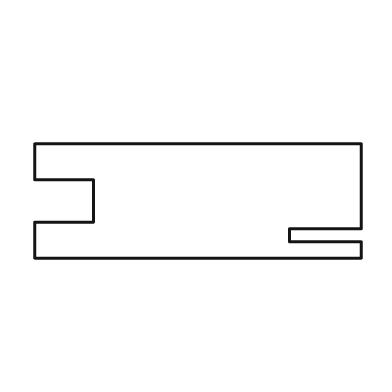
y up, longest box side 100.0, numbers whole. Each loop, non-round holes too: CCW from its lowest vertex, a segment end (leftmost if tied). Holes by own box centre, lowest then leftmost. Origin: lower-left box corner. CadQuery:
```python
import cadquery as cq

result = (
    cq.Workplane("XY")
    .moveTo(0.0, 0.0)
    .lineTo(100.0, 0.0)
    .lineTo(100.0, 5.0)
    .lineTo(78.0, 5.0)
    .lineTo(78.0, 9.0)
    .lineTo(100.0, 9.0)
    .lineTo(100.0, 35.0)
    .lineTo(0.0, 35.0)
    .lineTo(0.0, 24.0)
    .lineTo(18.0, 24.0)
    .lineTo(18.0, 11.0)
    .lineTo(0.0, 11.0)
    .close()
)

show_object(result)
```